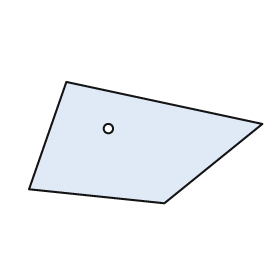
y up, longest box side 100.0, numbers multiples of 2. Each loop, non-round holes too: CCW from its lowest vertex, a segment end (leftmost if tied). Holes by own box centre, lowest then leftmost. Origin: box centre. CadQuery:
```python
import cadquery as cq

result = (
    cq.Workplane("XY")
    .moveTo(8.0, -26.0)
    .lineTo(50.0, 8.0)
    .lineTo(-34.0, 26.0)
    .lineTo(-50.0, -20.0)
    .close()
    .moveTo(-16.0, 6.0)
    .circle(2.0)
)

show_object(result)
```